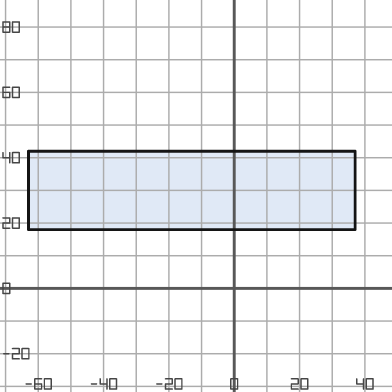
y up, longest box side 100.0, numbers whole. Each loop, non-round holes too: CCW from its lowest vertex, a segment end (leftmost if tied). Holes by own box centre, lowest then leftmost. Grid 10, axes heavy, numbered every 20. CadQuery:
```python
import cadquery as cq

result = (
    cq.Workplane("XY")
    .moveTo(-63.0, 18.0)
    .lineTo(37.0, 18.0)
    .lineTo(37.0, 42.0)
    .lineTo(-63.0, 42.0)
    .close()
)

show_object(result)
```